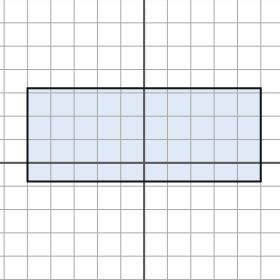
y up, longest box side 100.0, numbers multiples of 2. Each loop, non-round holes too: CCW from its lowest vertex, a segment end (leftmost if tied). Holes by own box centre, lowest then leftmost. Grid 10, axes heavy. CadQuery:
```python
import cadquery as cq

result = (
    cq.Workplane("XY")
    .moveTo(-50.0, -8.0)
    .lineTo(50.0, -8.0)
    .lineTo(50.0, 32.0)
    .lineTo(-50.0, 32.0)
    .close()
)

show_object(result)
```